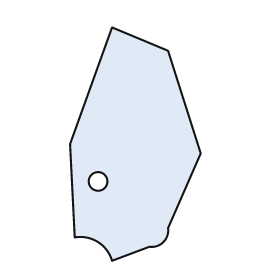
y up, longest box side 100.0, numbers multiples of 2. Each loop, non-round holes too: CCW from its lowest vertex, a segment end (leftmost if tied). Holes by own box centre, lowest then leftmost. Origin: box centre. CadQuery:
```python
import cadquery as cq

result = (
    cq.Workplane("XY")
    .moveTo(-10.0, -50.0)
    .lineTo(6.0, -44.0)
    .threePointArc((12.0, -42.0), (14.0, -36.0))
    .lineTo(28.0, -4.0)
    .lineTo(14.0, 40.0)
    .lineTo(-10.0, 50.0)
    .lineTo(-28.0, 0.0)
    .lineTo(-26.0, -40.0)
    .threePointArc((-16.0, -42.0), (-10.0, -50.0))
    .close()
    .moveTo(-16.0, -16.0)
    .circle(4.0)
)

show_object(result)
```